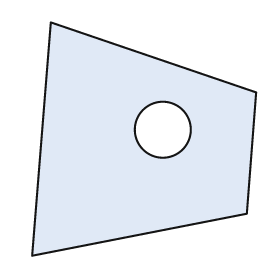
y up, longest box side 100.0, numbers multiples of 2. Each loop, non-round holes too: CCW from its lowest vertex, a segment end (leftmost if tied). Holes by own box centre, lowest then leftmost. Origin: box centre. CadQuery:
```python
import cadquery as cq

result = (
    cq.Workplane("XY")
    .moveTo(-48.0, -50.0)
    .lineTo(44.0, -32.0)
    .lineTo(48.0, 20.0)
    .lineTo(-40.0, 50.0)
    .close()
    .moveTo(8.0, 4.0)
    .circle(12.0)
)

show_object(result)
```